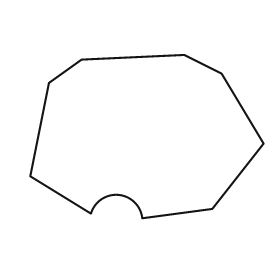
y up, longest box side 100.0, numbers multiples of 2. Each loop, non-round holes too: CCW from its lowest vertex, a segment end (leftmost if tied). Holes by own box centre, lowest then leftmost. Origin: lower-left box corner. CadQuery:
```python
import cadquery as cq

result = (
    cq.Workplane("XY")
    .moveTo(48.0, 0.0)
    .lineTo(78.0, 4.0)
    .lineTo(100.0, 32.0)
    .lineTo(82.0, 62.0)
    .lineTo(66.0, 70.0)
    .lineTo(22.0, 68.0)
    .lineTo(8.0, 58.0)
    .lineTo(0.0, 18.0)
    .lineTo(26.0, 2.0)
    .threePointArc((38.0, 10.0), (48.0, 0.0))
    .close()
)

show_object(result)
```